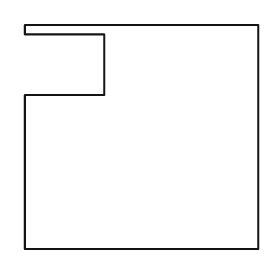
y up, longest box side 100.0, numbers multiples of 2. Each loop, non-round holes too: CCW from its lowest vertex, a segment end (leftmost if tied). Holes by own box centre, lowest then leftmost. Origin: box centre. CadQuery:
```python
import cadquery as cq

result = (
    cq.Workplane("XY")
    .moveTo(-50.0, -48.0)
    .lineTo(50.0, -48.0)
    .lineTo(50.0, 48.0)
    .lineTo(-50.0, 48.0)
    .lineTo(-50.0, 44.0)
    .lineTo(-16.0, 44.0)
    .lineTo(-16.0, 18.0)
    .lineTo(-50.0, 18.0)
    .close()
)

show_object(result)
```